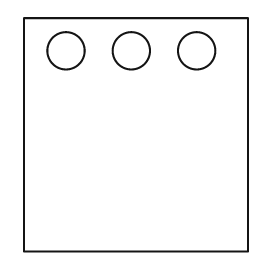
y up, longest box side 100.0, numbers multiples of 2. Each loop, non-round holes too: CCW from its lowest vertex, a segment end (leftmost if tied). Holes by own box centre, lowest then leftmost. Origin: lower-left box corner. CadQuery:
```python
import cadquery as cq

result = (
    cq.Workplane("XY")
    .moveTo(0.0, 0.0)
    .lineTo(96.0, 0.0)
    .lineTo(96.0, 100.0)
    .lineTo(0.0, 100.0)
    .close()
    .moveTo(18.0, 86.0)
    .circle(8.0)
    .moveTo(46.0, 86.0)
    .circle(8.0)
    .moveTo(74.0, 86.0)
    .circle(8.0)
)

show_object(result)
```